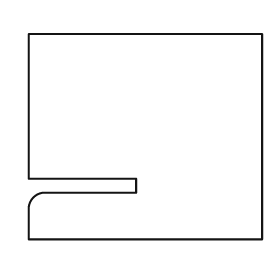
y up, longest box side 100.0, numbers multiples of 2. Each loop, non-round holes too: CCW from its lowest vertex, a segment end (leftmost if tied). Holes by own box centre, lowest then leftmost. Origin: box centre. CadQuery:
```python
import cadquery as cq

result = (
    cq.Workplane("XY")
    .moveTo(-50.0, -44.0)
    .lineTo(50.0, -44.0)
    .lineTo(50.0, 44.0)
    .lineTo(-50.0, 44.0)
    .lineTo(-50.0, -18.0)
    .lineTo(-4.0, -18.0)
    .lineTo(-4.0, -24.0)
    .lineTo(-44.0, -24.0)
    .threePointArc((-48.0, -26.0), (-50.0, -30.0))
    .close()
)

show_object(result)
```